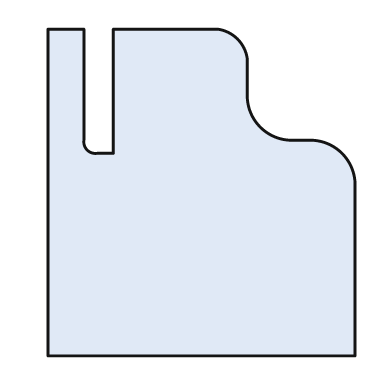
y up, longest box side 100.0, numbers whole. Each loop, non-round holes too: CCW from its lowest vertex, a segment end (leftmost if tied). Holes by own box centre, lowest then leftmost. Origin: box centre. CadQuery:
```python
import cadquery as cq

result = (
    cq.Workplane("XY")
    .moveTo(-47.0, -50.0)
    .lineTo(47.0, -50.0)
    .lineTo(47.0, 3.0)
    .threePointArc((43.0, 12.0), (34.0, 16.0))
    .lineTo(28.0, 16.0)
    .threePointArc((18.0, 20.0), (14.0, 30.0))
    .lineTo(14.0, 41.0)
    .threePointArc((11.0, 47.0), (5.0, 50.0))
    .lineTo(-27.0, 50.0)
    .lineTo(-27.0, 12.0)
    .lineTo(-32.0, 12.0)
    .threePointArc((-35.0, 13.0), (-36.0, 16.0))
    .lineTo(-36.0, 50.0)
    .lineTo(-47.0, 50.0)
    .close()
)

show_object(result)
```